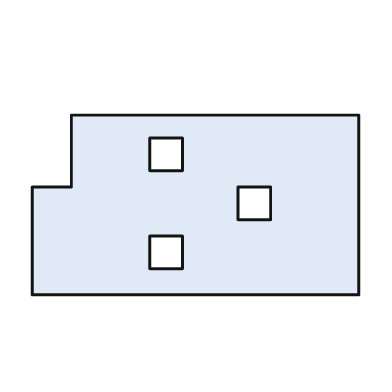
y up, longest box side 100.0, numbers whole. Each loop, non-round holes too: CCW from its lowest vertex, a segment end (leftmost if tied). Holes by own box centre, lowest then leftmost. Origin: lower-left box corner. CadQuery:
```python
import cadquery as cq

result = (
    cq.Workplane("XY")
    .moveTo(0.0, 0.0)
    .lineTo(100.0, 0.0)
    .lineTo(100.0, 55.0)
    .lineTo(12.0, 55.0)
    .lineTo(12.0, 33.0)
    .lineTo(0.0, 33.0)
    .close()
    .moveTo(36.0, 8.0)
    .lineTo(46.0, 8.0)
    .lineTo(46.0, 18.0)
    .lineTo(36.0, 18.0)
    .close()
    .moveTo(63.0, 23.0)
    .lineTo(73.0, 23.0)
    .lineTo(73.0, 33.0)
    .lineTo(63.0, 33.0)
    .close()
    .moveTo(36.0, 38.0)
    .lineTo(46.0, 38.0)
    .lineTo(46.0, 48.0)
    .lineTo(36.0, 48.0)
    .close()
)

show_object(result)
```